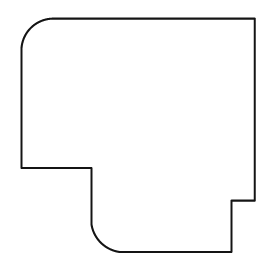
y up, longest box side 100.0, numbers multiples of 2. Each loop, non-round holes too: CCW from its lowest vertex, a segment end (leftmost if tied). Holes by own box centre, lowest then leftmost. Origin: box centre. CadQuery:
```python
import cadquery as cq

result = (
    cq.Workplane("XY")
    .moveTo(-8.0, -50.0)
    .lineTo(40.0, -50.0)
    .lineTo(40.0, -28.0)
    .lineTo(50.0, -28.0)
    .lineTo(50.0, 50.0)
    .lineTo(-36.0, 50.0)
    .threePointArc((-46.0, 46.0), (-50.0, 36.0))
    .lineTo(-50.0, -14.0)
    .lineTo(-20.0, -14.0)
    .lineTo(-20.0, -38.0)
    .threePointArc((-16.0, -46.0), (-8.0, -50.0))
    .close()
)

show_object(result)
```